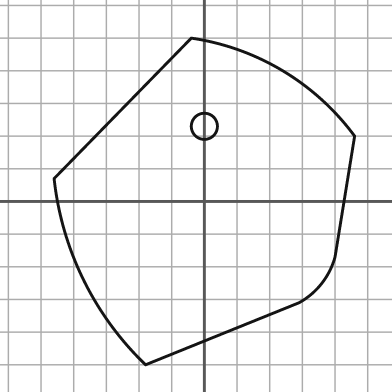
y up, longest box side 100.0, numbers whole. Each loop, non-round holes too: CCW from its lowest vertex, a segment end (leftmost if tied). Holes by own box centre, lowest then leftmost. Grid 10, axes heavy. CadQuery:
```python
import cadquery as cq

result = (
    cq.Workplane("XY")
    .moveTo(-18.0, -50.0)
    .lineTo(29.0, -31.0)
    .threePointArc((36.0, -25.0), (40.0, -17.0))
    .lineTo(46.0, 20.0)
    .threePointArc((24.0, 40.0), (-4.0, 50.0))
    .lineTo(-46.0, 7.0)
    .threePointArc((-37.0, -24.0), (-18.0, -50.0))
    .close()
    .moveTo(0.0, 23.0)
    .circle(4.0)
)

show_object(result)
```